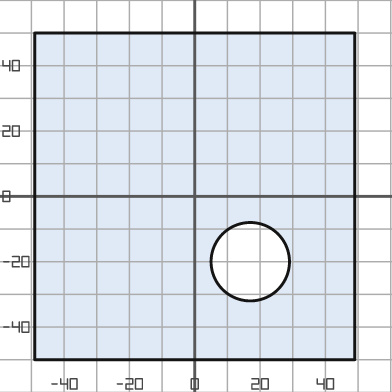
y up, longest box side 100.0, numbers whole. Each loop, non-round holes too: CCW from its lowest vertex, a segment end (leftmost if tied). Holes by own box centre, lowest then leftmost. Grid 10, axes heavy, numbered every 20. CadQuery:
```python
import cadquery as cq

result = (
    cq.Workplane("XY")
    .moveTo(-49.0, -50.0)
    .lineTo(49.0, -50.0)
    .lineTo(49.0, 50.0)
    .lineTo(-49.0, 50.0)
    .close()
    .moveTo(17.0, -20.0)
    .circle(12.0)
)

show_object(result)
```